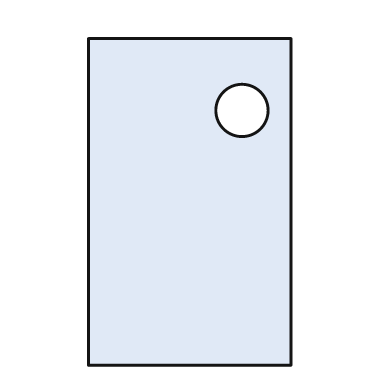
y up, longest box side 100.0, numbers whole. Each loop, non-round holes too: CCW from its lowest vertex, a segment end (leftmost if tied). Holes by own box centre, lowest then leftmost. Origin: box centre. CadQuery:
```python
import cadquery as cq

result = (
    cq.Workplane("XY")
    .moveTo(-31.0, -50.0)
    .lineTo(31.0, -50.0)
    .lineTo(31.0, 50.0)
    .lineTo(-31.0, 50.0)
    .close()
    .moveTo(16.0, 28.0)
    .circle(8.0)
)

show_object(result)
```